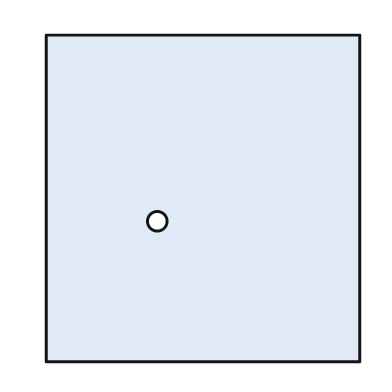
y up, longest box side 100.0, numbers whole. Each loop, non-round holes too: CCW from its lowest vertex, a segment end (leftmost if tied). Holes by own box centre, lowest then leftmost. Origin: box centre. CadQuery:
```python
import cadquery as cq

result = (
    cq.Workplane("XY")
    .moveTo(-48.0, -50.0)
    .lineTo(48.0, -50.0)
    .lineTo(48.0, 50.0)
    .lineTo(-48.0, 50.0)
    .close()
    .moveTo(-14.0, -7.0)
    .circle(3.0)
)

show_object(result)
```